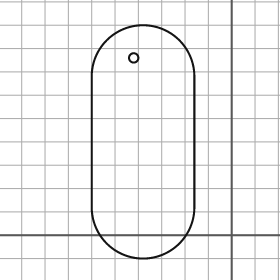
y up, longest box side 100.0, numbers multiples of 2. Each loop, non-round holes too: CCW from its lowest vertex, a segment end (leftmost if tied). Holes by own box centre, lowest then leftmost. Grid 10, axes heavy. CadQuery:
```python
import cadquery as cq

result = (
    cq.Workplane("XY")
    .moveTo(-60.0, 12.0)
    .threePointArc((-38.0, -10.0), (-16.0, 12.0))
    .lineTo(-16.0, 68.0)
    .threePointArc((-38.0, 90.0), (-60.0, 68.0))
    .close()
    .moveTo(-42.0, 76.0)
    .circle(2.0)
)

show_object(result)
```